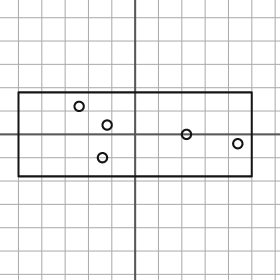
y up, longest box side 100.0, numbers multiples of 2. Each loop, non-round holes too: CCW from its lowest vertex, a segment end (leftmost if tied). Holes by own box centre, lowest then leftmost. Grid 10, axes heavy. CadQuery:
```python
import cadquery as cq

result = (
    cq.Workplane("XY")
    .moveTo(-50.0, -18.0)
    .lineTo(50.0, -18.0)
    .lineTo(50.0, 18.0)
    .lineTo(-50.0, 18.0)
    .close()
    .moveTo(-14.0, -10.0)
    .circle(2.0)
    .moveTo(44.0, -4.0)
    .circle(2.0)
    .moveTo(22.0, 0.0)
    .circle(2.0)
    .moveTo(-12.0, 4.0)
    .circle(2.0)
    .moveTo(-24.0, 12.0)
    .circle(2.0)
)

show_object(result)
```